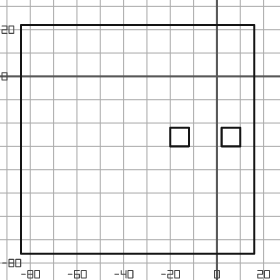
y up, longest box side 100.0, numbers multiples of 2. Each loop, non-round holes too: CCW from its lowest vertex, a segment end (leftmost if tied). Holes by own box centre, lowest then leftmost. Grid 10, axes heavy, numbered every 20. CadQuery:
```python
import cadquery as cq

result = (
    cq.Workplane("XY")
    .moveTo(-84.0, -76.0)
    .lineTo(16.0, -76.0)
    .lineTo(16.0, 22.0)
    .lineTo(-84.0, 22.0)
    .close()
    .moveTo(-20.0, -30.0)
    .lineTo(-12.0, -30.0)
    .lineTo(-12.0, -22.0)
    .lineTo(-20.0, -22.0)
    .close()
    .moveTo(2.0, -30.0)
    .lineTo(10.0, -30.0)
    .lineTo(10.0, -22.0)
    .lineTo(2.0, -22.0)
    .close()
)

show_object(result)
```